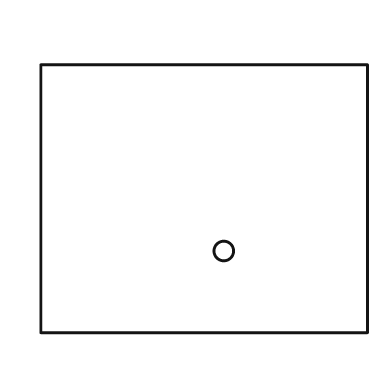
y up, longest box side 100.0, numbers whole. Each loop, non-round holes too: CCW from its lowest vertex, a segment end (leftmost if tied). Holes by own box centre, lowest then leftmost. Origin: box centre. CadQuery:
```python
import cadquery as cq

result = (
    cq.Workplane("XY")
    .moveTo(-50.0, -41.0)
    .lineTo(50.0, -41.0)
    .lineTo(50.0, 41.0)
    .lineTo(-50.0, 41.0)
    .close()
    .moveTo(6.0, -16.0)
    .circle(3.0)
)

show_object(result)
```